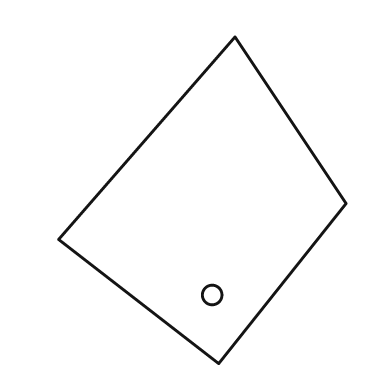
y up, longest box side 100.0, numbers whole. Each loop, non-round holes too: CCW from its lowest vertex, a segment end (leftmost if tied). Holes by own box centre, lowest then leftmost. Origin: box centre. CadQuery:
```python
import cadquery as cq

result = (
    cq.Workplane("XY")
    .moveTo(5.0, -50.0)
    .lineTo(44.0, -1.0)
    .lineTo(10.0, 50.0)
    .lineTo(-44.0, -12.0)
    .close()
    .moveTo(3.0, -29.0)
    .circle(3.0)
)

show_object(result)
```